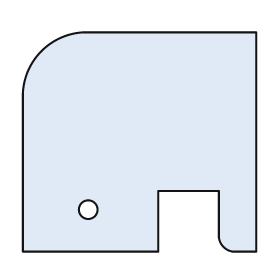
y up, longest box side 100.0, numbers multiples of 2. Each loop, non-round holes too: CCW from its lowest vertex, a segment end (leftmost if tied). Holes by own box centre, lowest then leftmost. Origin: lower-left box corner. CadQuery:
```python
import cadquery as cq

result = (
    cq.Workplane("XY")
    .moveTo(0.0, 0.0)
    .lineTo(58.0, 0.0)
    .lineTo(58.0, 26.0)
    .lineTo(84.0, 26.0)
    .lineTo(84.0, 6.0)
    .threePointArc((86.0, 2.0), (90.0, 0.0))
    .lineTo(100.0, 0.0)
    .lineTo(100.0, 94.0)
    .lineTo(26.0, 94.0)
    .threePointArc((8.0, 86.0), (0.0, 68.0))
    .close()
    .moveTo(28.0, 18.0)
    .circle(4.0)
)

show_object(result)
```